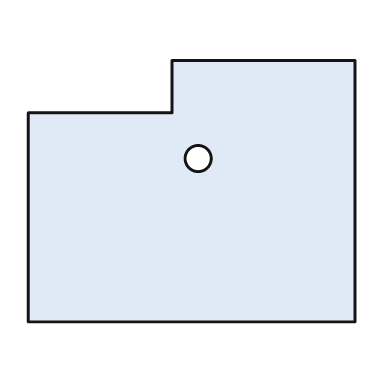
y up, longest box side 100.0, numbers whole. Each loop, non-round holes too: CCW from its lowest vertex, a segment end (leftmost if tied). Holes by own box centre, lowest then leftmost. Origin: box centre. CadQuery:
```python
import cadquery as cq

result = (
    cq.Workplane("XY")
    .moveTo(-50.0, -40.0)
    .lineTo(50.0, -40.0)
    .lineTo(50.0, 40.0)
    .lineTo(-6.0, 40.0)
    .lineTo(-6.0, 24.0)
    .lineTo(-50.0, 24.0)
    .close()
    .moveTo(2.0, 10.0)
    .circle(4.0)
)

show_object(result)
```